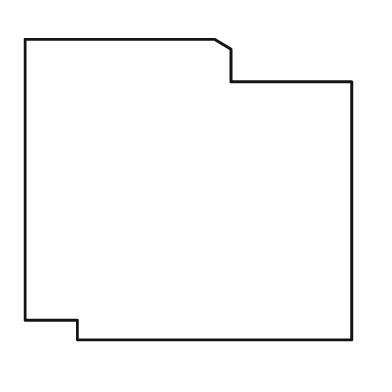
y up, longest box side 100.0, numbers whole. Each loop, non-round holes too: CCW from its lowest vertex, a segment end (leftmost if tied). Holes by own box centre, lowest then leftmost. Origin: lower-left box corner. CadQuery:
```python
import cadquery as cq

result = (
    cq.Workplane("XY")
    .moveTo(16.0, 0.0)
    .lineTo(100.0, 0.0)
    .lineTo(100.0, 79.0)
    .lineTo(63.0, 79.0)
    .lineTo(63.0, 89.0)
    .lineTo(58.0, 92.0)
    .lineTo(0.0, 92.0)
    .lineTo(0.0, 6.0)
    .lineTo(16.0, 6.0)
    .close()
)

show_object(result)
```